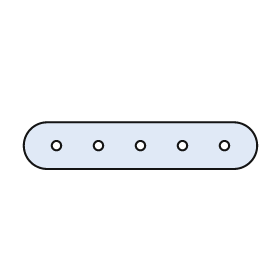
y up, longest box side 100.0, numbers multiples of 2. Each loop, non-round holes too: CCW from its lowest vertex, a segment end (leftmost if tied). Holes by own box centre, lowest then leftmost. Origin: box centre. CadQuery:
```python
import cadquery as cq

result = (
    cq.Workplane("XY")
    .moveTo(-40.0, -10.0)
    .lineTo(40.0, -10.0)
    .threePointArc((50.0, 0.0), (40.0, 10.0))
    .lineTo(-40.0, 10.0)
    .threePointArc((-50.0, 0.0), (-40.0, -10.0))
    .close()
    .moveTo(-36.0, 0.0)
    .circle(2.0)
    .moveTo(-18.0, 0.0)
    .circle(2.0)
    .moveTo(0.0, 0.0)
    .circle(2.0)
    .moveTo(18.0, 0.0)
    .circle(2.0)
    .moveTo(36.0, 0.0)
    .circle(2.0)
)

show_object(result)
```